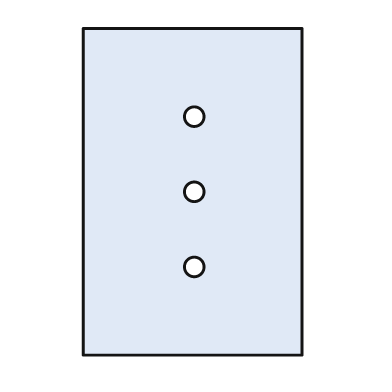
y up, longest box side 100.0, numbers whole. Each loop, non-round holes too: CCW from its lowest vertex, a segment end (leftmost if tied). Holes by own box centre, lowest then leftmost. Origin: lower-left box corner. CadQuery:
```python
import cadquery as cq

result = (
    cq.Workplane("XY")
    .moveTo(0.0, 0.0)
    .lineTo(67.0, 0.0)
    .lineTo(67.0, 100.0)
    .lineTo(0.0, 100.0)
    .close()
    .moveTo(34.0, 27.0)
    .circle(3.0)
    .moveTo(34.0, 50.0)
    .circle(3.0)
    .moveTo(34.0, 73.0)
    .circle(3.0)
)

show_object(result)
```